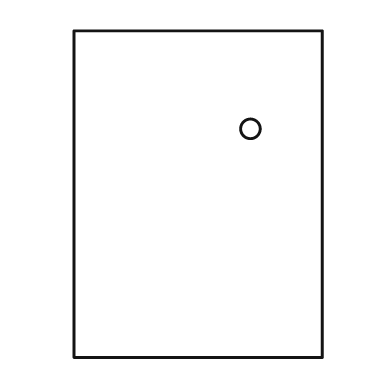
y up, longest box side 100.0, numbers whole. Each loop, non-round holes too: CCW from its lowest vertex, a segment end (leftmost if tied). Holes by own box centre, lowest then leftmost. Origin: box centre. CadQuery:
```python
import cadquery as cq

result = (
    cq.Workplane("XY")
    .moveTo(-38.0, -50.0)
    .lineTo(38.0, -50.0)
    .lineTo(38.0, 50.0)
    .lineTo(-38.0, 50.0)
    .close()
    .moveTo(16.0, 20.0)
    .circle(3.0)
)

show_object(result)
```